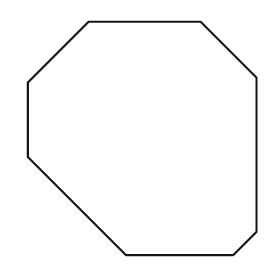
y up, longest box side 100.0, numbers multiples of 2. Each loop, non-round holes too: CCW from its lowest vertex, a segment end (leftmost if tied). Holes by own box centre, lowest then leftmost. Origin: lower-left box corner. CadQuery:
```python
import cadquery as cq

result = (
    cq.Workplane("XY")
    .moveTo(42.0, 0.0)
    .lineTo(88.0, 0.0)
    .lineTo(98.0, 10.0)
    .lineTo(98.0, 76.0)
    .lineTo(74.0, 100.0)
    .lineTo(26.0, 100.0)
    .lineTo(0.0, 74.0)
    .lineTo(0.0, 42.0)
    .close()
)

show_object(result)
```